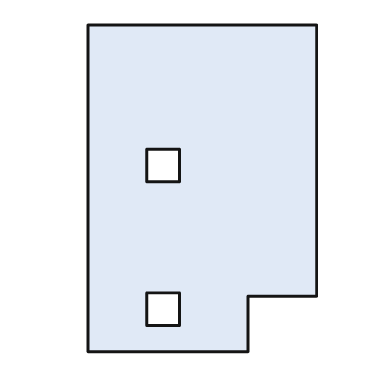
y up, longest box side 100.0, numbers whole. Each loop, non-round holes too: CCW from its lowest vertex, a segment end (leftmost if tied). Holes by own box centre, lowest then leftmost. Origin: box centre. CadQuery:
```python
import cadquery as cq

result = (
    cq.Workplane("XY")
    .moveTo(-35.0, -50.0)
    .lineTo(14.0, -50.0)
    .lineTo(14.0, -33.0)
    .lineTo(35.0, -33.0)
    .lineTo(35.0, 50.0)
    .lineTo(-35.0, 50.0)
    .close()
    .moveTo(-17.0, -42.0)
    .lineTo(-7.0, -42.0)
    .lineTo(-7.0, -32.0)
    .lineTo(-17.0, -32.0)
    .close()
    .moveTo(-17.0, 2.0)
    .lineTo(-7.0, 2.0)
    .lineTo(-7.0, 12.0)
    .lineTo(-17.0, 12.0)
    .close()
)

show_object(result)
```